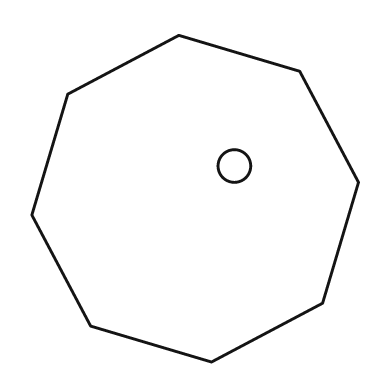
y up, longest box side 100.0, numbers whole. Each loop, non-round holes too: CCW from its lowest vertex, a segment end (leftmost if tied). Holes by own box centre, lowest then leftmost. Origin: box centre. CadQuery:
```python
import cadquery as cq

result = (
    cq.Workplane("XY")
    .moveTo(5.0, -50.0)
    .lineTo(39.0, -32.0)
    .lineTo(50.0, 5.0)
    .lineTo(32.0, 39.0)
    .lineTo(-5.0, 50.0)
    .lineTo(-39.0, 32.0)
    .lineTo(-50.0, -5.0)
    .lineTo(-32.0, -39.0)
    .close()
    .moveTo(12.0, 10.0)
    .circle(5.0)
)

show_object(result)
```